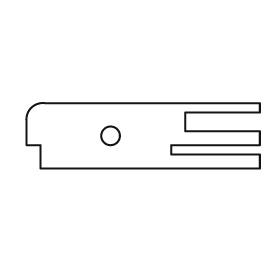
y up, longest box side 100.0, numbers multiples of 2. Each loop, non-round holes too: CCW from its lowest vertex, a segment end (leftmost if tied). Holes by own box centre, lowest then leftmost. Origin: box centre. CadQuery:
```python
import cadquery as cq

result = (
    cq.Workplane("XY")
    .moveTo(-44.0, -14.0)
    .lineTo(50.0, -14.0)
    .lineTo(50.0, -8.0)
    .lineTo(12.0, -8.0)
    .lineTo(12.0, -4.0)
    .lineTo(50.0, -4.0)
    .lineTo(50.0, 2.0)
    .lineTo(18.0, 2.0)
    .lineTo(18.0, 10.0)
    .lineTo(50.0, 10.0)
    .lineTo(50.0, 14.0)
    .lineTo(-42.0, 14.0)
    .threePointArc((-48.0, 12.0), (-50.0, 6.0))
    .lineTo(-50.0, -4.0)
    .lineTo(-44.0, -4.0)
    .close()
    .moveTo(-14.0, 0.0)
    .circle(4.0)
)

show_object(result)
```